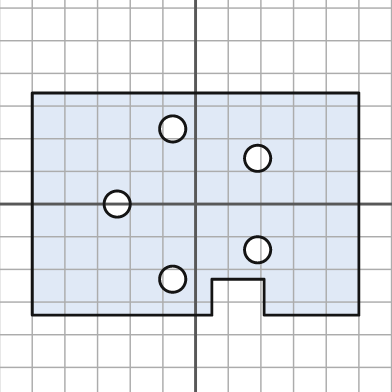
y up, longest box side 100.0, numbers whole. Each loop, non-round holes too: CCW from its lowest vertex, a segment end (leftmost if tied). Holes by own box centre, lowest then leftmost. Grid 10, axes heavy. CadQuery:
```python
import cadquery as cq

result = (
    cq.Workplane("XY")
    .moveTo(-50.0, -34.0)
    .lineTo(5.0, -34.0)
    .lineTo(5.0, -23.0)
    .lineTo(21.0, -23.0)
    .lineTo(21.0, -34.0)
    .lineTo(50.0, -34.0)
    .lineTo(50.0, 34.0)
    .lineTo(-50.0, 34.0)
    .close()
    .moveTo(-7.0, -23.0)
    .circle(4.0)
    .moveTo(19.0, -14.0)
    .circle(4.0)
    .moveTo(-24.0, 0.0)
    .circle(4.0)
    .moveTo(19.0, 14.0)
    .circle(4.0)
    .moveTo(-7.0, 23.0)
    .circle(4.0)
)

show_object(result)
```